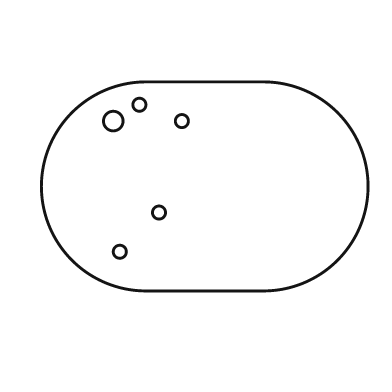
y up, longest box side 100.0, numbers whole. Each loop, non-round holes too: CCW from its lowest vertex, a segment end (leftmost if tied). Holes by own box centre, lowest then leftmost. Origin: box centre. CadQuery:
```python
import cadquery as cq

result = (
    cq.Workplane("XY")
    .moveTo(-18.0, -32.0)
    .lineTo(18.0, -32.0)
    .threePointArc((50.0, 0.0), (18.0, 32.0))
    .lineTo(-18.0, 32.0)
    .threePointArc((-50.0, 0.0), (-18.0, -32.0))
    .close()
    .moveTo(-26.0, -20.0)
    .circle(2.0)
    .moveTo(-14.0, -8.0)
    .circle(2.0)
    .moveTo(-28.0, 20.0)
    .circle(3.0)
    .moveTo(-7.0, 20.0)
    .circle(2.0)
    .moveTo(-20.0, 25.0)
    .circle(2.0)
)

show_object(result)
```